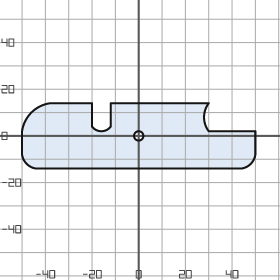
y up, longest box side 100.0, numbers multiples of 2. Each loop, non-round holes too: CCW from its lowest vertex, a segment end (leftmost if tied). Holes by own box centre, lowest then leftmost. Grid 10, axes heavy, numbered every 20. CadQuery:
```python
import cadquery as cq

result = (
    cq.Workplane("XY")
    .moveTo(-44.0, -14.0)
    .lineTo(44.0, -14.0)
    .threePointArc((48.0, -12.0), (50.0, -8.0))
    .lineTo(50.0, 2.0)
    .lineTo(30.0, 2.0)
    .threePointArc((28.0, 8.0), (30.0, 14.0))
    .lineTo(-12.0, 14.0)
    .lineTo(-12.0, 4.0)
    .threePointArc((-16.0, 2.0), (-20.0, 4.0))
    .lineTo(-20.0, 14.0)
    .lineTo(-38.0, 14.0)
    .threePointArc((-46.0, 10.0), (-50.0, 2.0))
    .lineTo(-50.0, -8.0)
    .threePointArc((-48.0, -12.0), (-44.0, -14.0))
    .close()
    .moveTo(0.0, 0.0)
    .circle(2.0)
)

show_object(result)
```